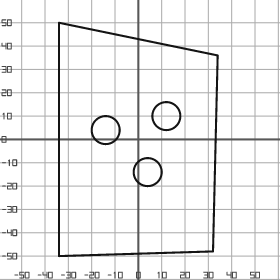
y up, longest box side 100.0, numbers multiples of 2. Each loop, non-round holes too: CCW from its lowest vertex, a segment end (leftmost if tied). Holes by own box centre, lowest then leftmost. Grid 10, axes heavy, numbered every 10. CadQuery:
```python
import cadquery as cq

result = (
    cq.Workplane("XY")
    .moveTo(-34.0, -50.0)
    .lineTo(32.0, -48.0)
    .lineTo(34.0, 36.0)
    .lineTo(-34.0, 50.0)
    .close()
    .moveTo(4.0, -14.0)
    .circle(6.0)
    .moveTo(-14.0, 4.0)
    .circle(6.0)
    .moveTo(12.0, 10.0)
    .circle(6.0)
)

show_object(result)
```